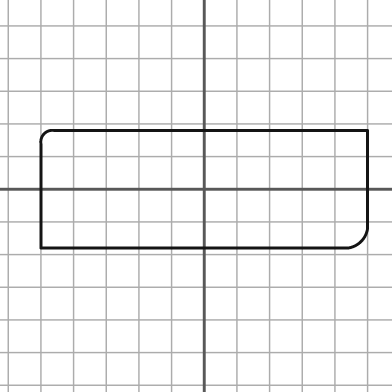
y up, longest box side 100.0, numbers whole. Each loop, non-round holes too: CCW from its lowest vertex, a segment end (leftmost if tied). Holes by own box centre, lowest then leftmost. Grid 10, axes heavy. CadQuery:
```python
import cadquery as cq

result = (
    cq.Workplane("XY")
    .moveTo(-50.0, -18.0)
    .lineTo(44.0, -18.0)
    .threePointArc((48.0, -16.0), (50.0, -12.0))
    .lineTo(50.0, 18.0)
    .lineTo(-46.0, 18.0)
    .threePointArc((-49.0, 17.0), (-50.0, 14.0))
    .close()
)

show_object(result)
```